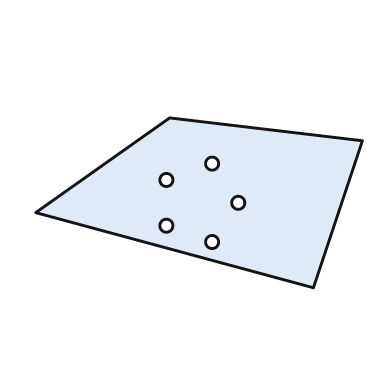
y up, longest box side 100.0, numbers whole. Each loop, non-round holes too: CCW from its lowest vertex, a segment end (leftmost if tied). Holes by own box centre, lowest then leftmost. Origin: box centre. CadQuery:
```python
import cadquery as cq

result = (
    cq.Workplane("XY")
    .moveTo(35.0, -26.0)
    .lineTo(50.0, 19.0)
    .lineTo(-9.0, 26.0)
    .lineTo(-50.0, -3.0)
    .close()
    .moveTo(4.0, -12.0)
    .circle(2.0)
    .moveTo(-10.0, -7.0)
    .circle(2.0)
    .moveTo(12.0, 0.0)
    .circle(2.0)
    .moveTo(-10.0, 7.0)
    .circle(2.0)
    .moveTo(4.0, 12.0)
    .circle(2.0)
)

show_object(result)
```